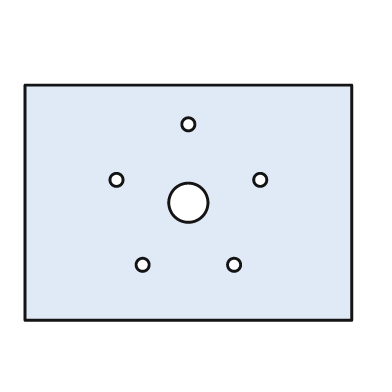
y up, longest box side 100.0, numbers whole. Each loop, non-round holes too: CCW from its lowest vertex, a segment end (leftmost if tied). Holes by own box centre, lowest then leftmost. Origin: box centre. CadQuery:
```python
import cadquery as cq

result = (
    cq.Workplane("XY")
    .moveTo(-50.0, -36.0)
    .lineTo(50.0, -36.0)
    .lineTo(50.0, 36.0)
    .lineTo(-50.0, 36.0)
    .close()
    .moveTo(-14.0, -19.0)
    .circle(2.0)
    .moveTo(14.0, -19.0)
    .circle(2.0)
    .moveTo(0.0, 0.0)
    .circle(6.0)
    .moveTo(-22.0, 7.0)
    .circle(2.0)
    .moveTo(22.0, 7.0)
    .circle(2.0)
    .moveTo(0.0, 24.0)
    .circle(2.0)
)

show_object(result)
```